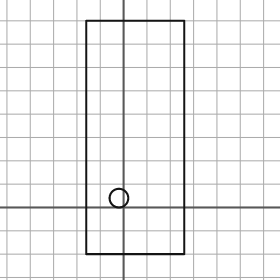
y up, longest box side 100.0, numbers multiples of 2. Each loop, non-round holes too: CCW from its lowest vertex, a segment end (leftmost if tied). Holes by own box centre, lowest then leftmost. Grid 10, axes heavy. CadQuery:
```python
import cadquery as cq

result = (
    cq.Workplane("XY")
    .moveTo(-16.0, -20.0)
    .lineTo(26.0, -20.0)
    .lineTo(26.0, 80.0)
    .lineTo(-16.0, 80.0)
    .close()
    .moveTo(-2.0, 4.0)
    .circle(4.0)
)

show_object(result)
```